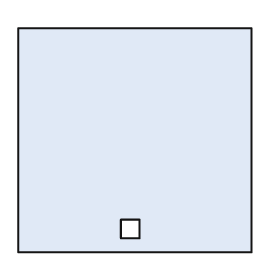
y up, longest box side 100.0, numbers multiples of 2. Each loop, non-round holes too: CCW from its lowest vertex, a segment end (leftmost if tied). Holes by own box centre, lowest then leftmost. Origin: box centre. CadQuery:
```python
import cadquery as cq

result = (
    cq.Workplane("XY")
    .moveTo(-50.0, -48.0)
    .lineTo(50.0, -48.0)
    .lineTo(50.0, 48.0)
    .lineTo(-50.0, 48.0)
    .close()
    .moveTo(-6.0, -42.0)
    .lineTo(2.0, -42.0)
    .lineTo(2.0, -34.0)
    .lineTo(-6.0, -34.0)
    .close()
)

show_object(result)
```